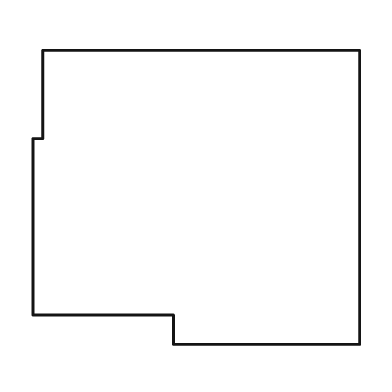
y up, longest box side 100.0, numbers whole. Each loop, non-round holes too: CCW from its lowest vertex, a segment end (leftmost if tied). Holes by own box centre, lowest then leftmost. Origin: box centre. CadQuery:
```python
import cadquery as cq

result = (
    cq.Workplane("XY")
    .moveTo(-7.0, -45.0)
    .lineTo(50.0, -45.0)
    .lineTo(50.0, 45.0)
    .lineTo(-47.0, 45.0)
    .lineTo(-47.0, 18.0)
    .lineTo(-50.0, 18.0)
    .lineTo(-50.0, -36.0)
    .lineTo(-7.0, -36.0)
    .close()
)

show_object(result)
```